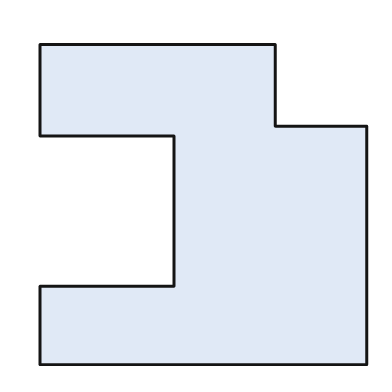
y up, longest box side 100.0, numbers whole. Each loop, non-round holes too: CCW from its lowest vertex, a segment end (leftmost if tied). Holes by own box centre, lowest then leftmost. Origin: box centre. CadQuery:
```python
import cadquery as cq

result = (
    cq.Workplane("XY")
    .moveTo(-50.0, -49.0)
    .lineTo(50.0, -49.0)
    .lineTo(50.0, 24.0)
    .lineTo(22.0, 24.0)
    .lineTo(22.0, 49.0)
    .lineTo(-50.0, 49.0)
    .lineTo(-50.0, 21.0)
    .lineTo(-9.0, 21.0)
    .lineTo(-9.0, -25.0)
    .lineTo(-50.0, -25.0)
    .close()
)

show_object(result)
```